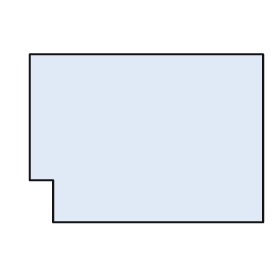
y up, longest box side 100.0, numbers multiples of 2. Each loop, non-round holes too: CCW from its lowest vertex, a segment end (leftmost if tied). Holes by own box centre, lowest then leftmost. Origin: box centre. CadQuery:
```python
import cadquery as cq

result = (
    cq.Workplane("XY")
    .moveTo(-40.0, -36.0)
    .lineTo(50.0, -36.0)
    .lineTo(50.0, 36.0)
    .lineTo(-50.0, 36.0)
    .lineTo(-50.0, -18.0)
    .lineTo(-40.0, -18.0)
    .close()
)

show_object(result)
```